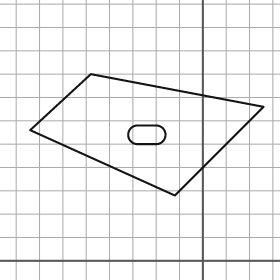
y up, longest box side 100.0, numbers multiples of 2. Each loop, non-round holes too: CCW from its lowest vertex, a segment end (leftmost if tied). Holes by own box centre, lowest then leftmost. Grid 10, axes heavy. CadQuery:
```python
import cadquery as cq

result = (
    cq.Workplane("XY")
    .moveTo(-12.0, 28.0)
    .lineTo(26.0, 66.0)
    .lineTo(-48.0, 80.0)
    .lineTo(-74.0, 56.0)
    .close()
    .moveTo(-28.0, 50.0)
    .lineTo(-20.0, 50.0)
    .threePointArc((-16.0, 54.0), (-20.0, 58.0))
    .lineTo(-28.0, 58.0)
    .threePointArc((-32.0, 54.0), (-28.0, 50.0))
    .close()
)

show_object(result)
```